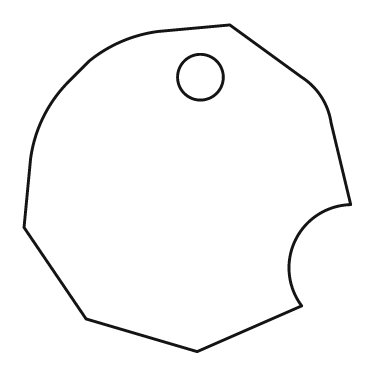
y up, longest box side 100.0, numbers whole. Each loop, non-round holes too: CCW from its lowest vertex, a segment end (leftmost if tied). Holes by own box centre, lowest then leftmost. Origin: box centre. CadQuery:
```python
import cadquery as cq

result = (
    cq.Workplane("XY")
    .moveTo(3.0, -50.0)
    .lineTo(35.0, -36.0)
    .threePointArc((33.0, -16.0), (50.0, -5.0))
    .lineTo(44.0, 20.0)
    .threePointArc((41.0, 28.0), (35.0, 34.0))
    .lineTo(13.0, 50.0)
    .lineTo(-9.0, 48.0)
    .threePointArc((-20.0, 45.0), (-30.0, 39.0))
    .lineTo(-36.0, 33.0)
    .threePointArc((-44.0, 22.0), (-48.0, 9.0))
    .lineTo(-50.0, -12.0)
    .lineTo(-31.0, -40.0)
    .close()
    .moveTo(4.0, 34.0)
    .circle(7.0)
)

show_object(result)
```